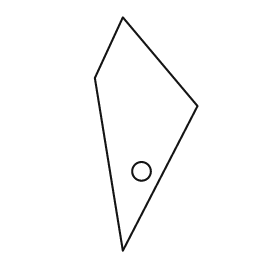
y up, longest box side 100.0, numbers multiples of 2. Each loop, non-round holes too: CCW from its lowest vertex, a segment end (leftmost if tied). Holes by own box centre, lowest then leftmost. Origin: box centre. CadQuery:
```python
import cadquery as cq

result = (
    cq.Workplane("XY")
    .moveTo(-10.0, -50.0)
    .lineTo(22.0, 12.0)
    .lineTo(-10.0, 50.0)
    .lineTo(-22.0, 24.0)
    .close()
    .moveTo(-2.0, -16.0)
    .circle(4.0)
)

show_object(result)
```